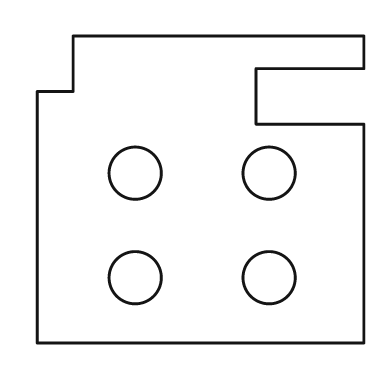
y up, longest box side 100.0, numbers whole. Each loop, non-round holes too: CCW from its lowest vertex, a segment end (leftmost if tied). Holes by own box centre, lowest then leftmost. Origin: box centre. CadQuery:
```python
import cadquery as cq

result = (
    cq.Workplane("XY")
    .moveTo(-50.0, -47.0)
    .lineTo(50.0, -47.0)
    .lineTo(50.0, 20.0)
    .lineTo(17.0, 20.0)
    .lineTo(17.0, 37.0)
    .lineTo(50.0, 37.0)
    .lineTo(50.0, 47.0)
    .lineTo(-39.0, 47.0)
    .lineTo(-39.0, 30.0)
    .lineTo(-50.0, 30.0)
    .close()
    .moveTo(-20.0, -27.0)
    .circle(8.0)
    .moveTo(21.0, -27.0)
    .circle(8.0)
    .moveTo(-20.0, 5.0)
    .circle(8.0)
    .moveTo(21.0, 5.0)
    .circle(8.0)
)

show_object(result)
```